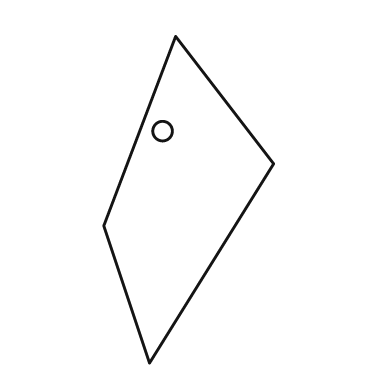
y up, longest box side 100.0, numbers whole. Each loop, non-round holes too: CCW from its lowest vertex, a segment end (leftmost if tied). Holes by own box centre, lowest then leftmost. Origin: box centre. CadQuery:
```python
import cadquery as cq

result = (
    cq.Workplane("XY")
    .moveTo(-12.0, -50.0)
    .lineTo(26.0, 11.0)
    .lineTo(-4.0, 50.0)
    .lineTo(-26.0, -8.0)
    .close()
    .moveTo(-8.0, 21.0)
    .circle(3.0)
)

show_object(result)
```